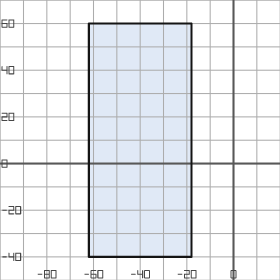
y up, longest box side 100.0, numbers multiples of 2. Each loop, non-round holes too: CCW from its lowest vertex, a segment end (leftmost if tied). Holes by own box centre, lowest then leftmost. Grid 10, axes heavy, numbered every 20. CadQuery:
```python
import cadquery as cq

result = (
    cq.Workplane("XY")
    .moveTo(-62.0, -40.0)
    .lineTo(-18.0, -40.0)
    .lineTo(-18.0, 60.0)
    .lineTo(-62.0, 60.0)
    .close()
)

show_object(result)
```